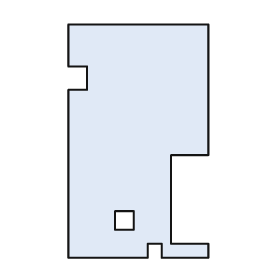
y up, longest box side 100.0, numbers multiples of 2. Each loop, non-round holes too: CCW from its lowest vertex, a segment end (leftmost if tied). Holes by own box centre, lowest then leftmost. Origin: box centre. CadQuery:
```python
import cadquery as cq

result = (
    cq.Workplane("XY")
    .moveTo(-30.0, -50.0)
    .lineTo(4.0, -50.0)
    .lineTo(4.0, -44.0)
    .lineTo(10.0, -44.0)
    .lineTo(10.0, -50.0)
    .lineTo(30.0, -50.0)
    .lineTo(30.0, -44.0)
    .lineTo(14.0, -44.0)
    .lineTo(14.0, -6.0)
    .lineTo(30.0, -6.0)
    .lineTo(30.0, 50.0)
    .lineTo(-30.0, 50.0)
    .lineTo(-30.0, 32.0)
    .lineTo(-22.0, 32.0)
    .lineTo(-22.0, 22.0)
    .lineTo(-30.0, 22.0)
    .close()
    .moveTo(-10.0, -38.0)
    .lineTo(-2.0, -38.0)
    .lineTo(-2.0, -30.0)
    .lineTo(-10.0, -30.0)
    .close()
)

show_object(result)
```